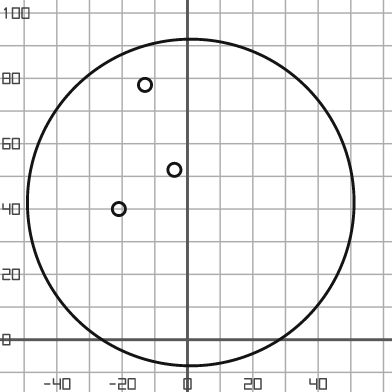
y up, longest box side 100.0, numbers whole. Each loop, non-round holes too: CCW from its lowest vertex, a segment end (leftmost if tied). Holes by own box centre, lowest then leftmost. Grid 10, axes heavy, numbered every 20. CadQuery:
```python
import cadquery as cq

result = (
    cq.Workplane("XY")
    .moveTo(1.0, 42.0)
    .circle(50.0)
    .moveTo(-21.0, 40.0)
    .circle(2.0)
    .moveTo(-4.0, 52.0)
    .circle(2.0)
    .moveTo(-13.0, 78.0)
    .circle(2.0)
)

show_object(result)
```